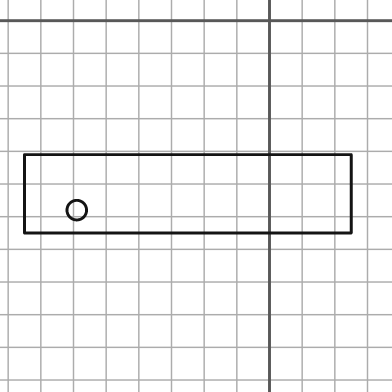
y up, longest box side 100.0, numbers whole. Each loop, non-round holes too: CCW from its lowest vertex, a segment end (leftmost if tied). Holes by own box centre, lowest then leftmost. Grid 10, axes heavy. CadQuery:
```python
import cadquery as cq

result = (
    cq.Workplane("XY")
    .moveTo(-75.0, -65.0)
    .lineTo(25.0, -65.0)
    .lineTo(25.0, -41.0)
    .lineTo(-75.0, -41.0)
    .close()
    .moveTo(-59.0, -58.0)
    .circle(3.0)
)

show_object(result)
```